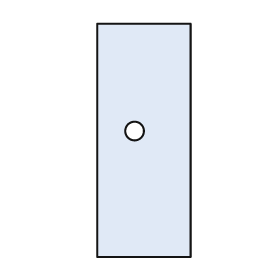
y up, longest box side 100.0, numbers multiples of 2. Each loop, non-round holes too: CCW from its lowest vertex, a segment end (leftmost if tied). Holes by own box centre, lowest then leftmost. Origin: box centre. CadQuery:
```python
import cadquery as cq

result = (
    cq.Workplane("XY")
    .moveTo(-20.0, -50.0)
    .lineTo(20.0, -50.0)
    .lineTo(20.0, 50.0)
    .lineTo(-20.0, 50.0)
    .close()
    .moveTo(-4.0, 4.0)
    .circle(4.0)
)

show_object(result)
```